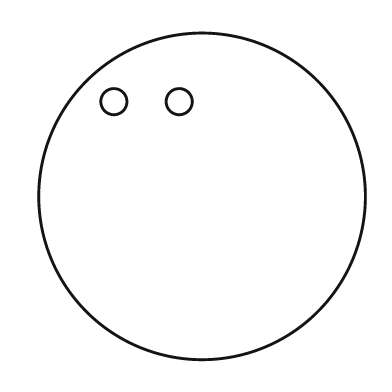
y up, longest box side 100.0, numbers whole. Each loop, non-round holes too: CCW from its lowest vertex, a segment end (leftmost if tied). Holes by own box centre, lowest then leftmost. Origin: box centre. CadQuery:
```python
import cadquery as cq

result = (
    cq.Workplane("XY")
    .moveTo(0.0, 0.0)
    .circle(50.0)
    .moveTo(-27.0, 29.0)
    .circle(4.0)
    .moveTo(-7.0, 29.0)
    .circle(4.0)
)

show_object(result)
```